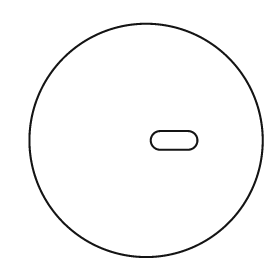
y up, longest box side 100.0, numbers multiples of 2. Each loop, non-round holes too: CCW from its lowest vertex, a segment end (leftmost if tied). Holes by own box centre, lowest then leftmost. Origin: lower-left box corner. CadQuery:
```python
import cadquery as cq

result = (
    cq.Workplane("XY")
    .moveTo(50.0, 50.0)
    .circle(50.0)
    .moveTo(56.0, 46.0)
    .lineTo(68.0, 46.0)
    .threePointArc((72.0, 50.0), (68.0, 54.0))
    .lineTo(56.0, 54.0)
    .threePointArc((52.0, 50.0), (56.0, 46.0))
    .close()
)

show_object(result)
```